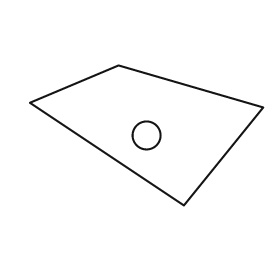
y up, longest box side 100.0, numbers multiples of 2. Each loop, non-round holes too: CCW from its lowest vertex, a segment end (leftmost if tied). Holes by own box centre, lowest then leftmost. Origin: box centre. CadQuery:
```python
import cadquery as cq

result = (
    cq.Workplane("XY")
    .moveTo(16.0, -30.0)
    .lineTo(50.0, 12.0)
    .lineTo(-12.0, 30.0)
    .lineTo(-50.0, 14.0)
    .close()
    .moveTo(0.0, 0.0)
    .circle(6.0)
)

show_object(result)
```